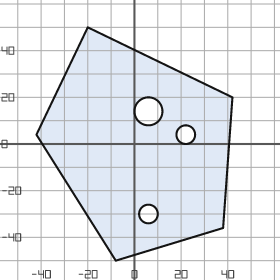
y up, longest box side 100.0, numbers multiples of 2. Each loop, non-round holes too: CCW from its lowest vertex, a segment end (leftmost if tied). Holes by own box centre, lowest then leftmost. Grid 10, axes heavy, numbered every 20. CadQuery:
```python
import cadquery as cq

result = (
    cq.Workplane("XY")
    .moveTo(-8.0, -50.0)
    .lineTo(38.0, -36.0)
    .lineTo(42.0, 20.0)
    .lineTo(-20.0, 50.0)
    .lineTo(-42.0, 4.0)
    .close()
    .moveTo(6.0, -30.0)
    .circle(4.0)
    .moveTo(22.0, 4.0)
    .circle(4.0)
    .moveTo(6.0, 14.0)
    .circle(6.0)
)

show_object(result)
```